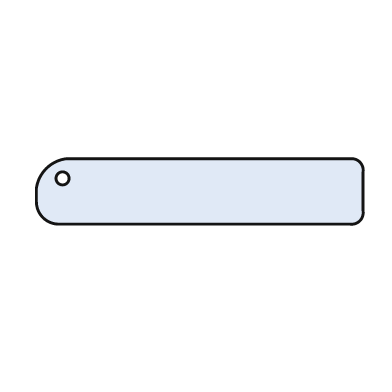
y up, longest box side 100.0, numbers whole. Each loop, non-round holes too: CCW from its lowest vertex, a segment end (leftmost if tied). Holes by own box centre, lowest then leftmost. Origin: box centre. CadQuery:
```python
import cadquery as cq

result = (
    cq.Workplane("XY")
    .moveTo(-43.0, -10.0)
    .lineTo(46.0, -10.0)
    .threePointArc((49.0, -9.0), (50.0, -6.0))
    .lineTo(50.0, 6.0)
    .threePointArc((49.0, 9.0), (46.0, 10.0))
    .lineTo(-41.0, 10.0)
    .threePointArc((-47.0, 7.0), (-50.0, 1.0))
    .lineTo(-50.0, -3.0)
    .threePointArc((-48.0, -8.0), (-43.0, -10.0))
    .close()
    .moveTo(-42.0, 4.0)
    .circle(2.0)
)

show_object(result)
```